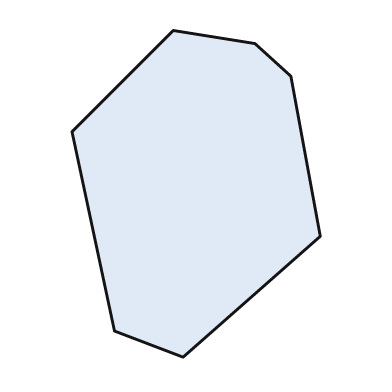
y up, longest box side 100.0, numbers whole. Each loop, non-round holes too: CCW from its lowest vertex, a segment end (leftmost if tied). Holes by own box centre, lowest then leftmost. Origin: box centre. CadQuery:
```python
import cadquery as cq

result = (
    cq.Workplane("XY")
    .moveTo(-4.0, -50.0)
    .lineTo(38.0, -13.0)
    .lineTo(29.0, 36.0)
    .lineTo(18.0, 46.0)
    .lineTo(-7.0, 50.0)
    .lineTo(-38.0, 19.0)
    .lineTo(-25.0, -42.0)
    .close()
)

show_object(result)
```